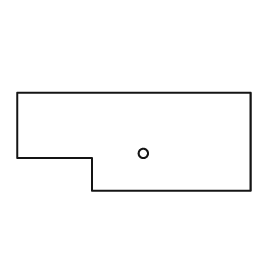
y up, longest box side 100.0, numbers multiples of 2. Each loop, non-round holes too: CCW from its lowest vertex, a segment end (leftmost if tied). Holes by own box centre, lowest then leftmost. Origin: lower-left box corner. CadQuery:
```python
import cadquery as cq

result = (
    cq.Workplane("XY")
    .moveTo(32.0, 0.0)
    .lineTo(100.0, 0.0)
    .lineTo(100.0, 42.0)
    .lineTo(0.0, 42.0)
    .lineTo(0.0, 14.0)
    .lineTo(32.0, 14.0)
    .close()
    .moveTo(54.0, 16.0)
    .circle(2.0)
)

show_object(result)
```